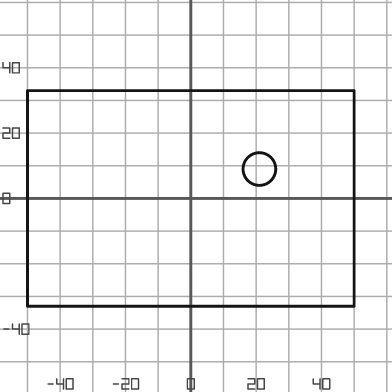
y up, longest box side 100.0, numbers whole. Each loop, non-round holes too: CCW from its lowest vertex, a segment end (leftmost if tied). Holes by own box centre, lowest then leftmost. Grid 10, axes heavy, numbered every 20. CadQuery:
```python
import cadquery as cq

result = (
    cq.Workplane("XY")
    .moveTo(-50.0, -33.0)
    .lineTo(50.0, -33.0)
    .lineTo(50.0, 33.0)
    .lineTo(-50.0, 33.0)
    .close()
    .moveTo(21.0, 9.0)
    .circle(5.0)
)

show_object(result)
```